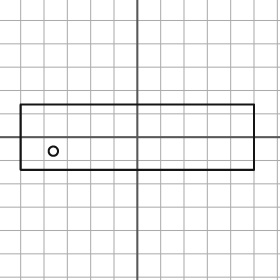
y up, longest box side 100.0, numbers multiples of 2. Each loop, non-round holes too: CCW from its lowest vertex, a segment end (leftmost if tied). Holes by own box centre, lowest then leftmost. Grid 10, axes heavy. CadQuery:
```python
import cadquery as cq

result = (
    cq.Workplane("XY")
    .moveTo(-50.0, -14.0)
    .lineTo(50.0, -14.0)
    .lineTo(50.0, 14.0)
    .lineTo(-50.0, 14.0)
    .close()
    .moveTo(-36.0, -6.0)
    .circle(2.0)
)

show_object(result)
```